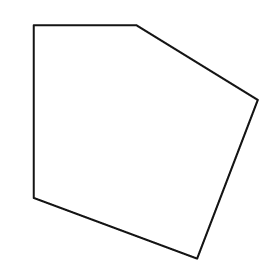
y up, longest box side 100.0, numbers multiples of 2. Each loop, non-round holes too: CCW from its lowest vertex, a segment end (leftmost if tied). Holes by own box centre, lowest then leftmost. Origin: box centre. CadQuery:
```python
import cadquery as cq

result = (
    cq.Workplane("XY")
    .moveTo(22.0, -50.0)
    .lineTo(48.0, 18.0)
    .lineTo(-4.0, 50.0)
    .lineTo(-48.0, 50.0)
    .lineTo(-48.0, -24.0)
    .close()
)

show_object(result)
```